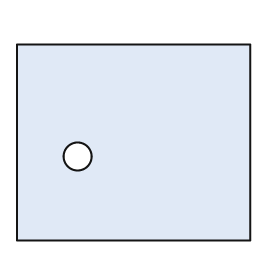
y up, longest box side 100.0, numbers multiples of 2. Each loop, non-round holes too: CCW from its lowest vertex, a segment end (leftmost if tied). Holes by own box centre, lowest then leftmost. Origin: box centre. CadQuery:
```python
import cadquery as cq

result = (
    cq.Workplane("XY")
    .moveTo(-50.0, -42.0)
    .lineTo(50.0, -42.0)
    .lineTo(50.0, 42.0)
    .lineTo(-50.0, 42.0)
    .close()
    .moveTo(-24.0, -6.0)
    .circle(6.0)
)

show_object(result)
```